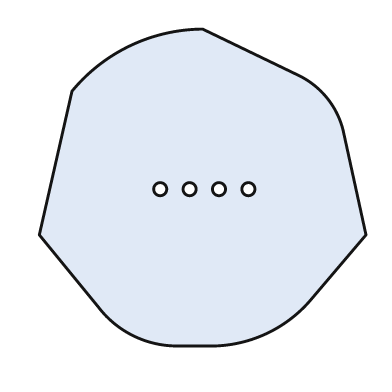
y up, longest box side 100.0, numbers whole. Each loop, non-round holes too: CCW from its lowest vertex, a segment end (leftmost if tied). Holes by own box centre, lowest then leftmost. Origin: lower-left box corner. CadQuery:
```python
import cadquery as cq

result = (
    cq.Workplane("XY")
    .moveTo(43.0, 0.0)
    .lineTo(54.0, 0.0)
    .threePointArc((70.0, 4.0), (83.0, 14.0))
    .lineTo(100.0, 34.0)
    .lineTo(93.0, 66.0)
    .threePointArc((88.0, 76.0), (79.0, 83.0))
    .lineTo(50.0, 97.0)
    .threePointArc((28.0, 92.0), (10.0, 78.0))
    .lineTo(0.0, 34.0)
    .lineTo(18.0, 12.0)
    .threePointArc((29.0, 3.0), (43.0, 0.0))
    .close()
    .moveTo(37.0, 48.0)
    .circle(2.0)
    .moveTo(46.0, 48.0)
    .circle(2.0)
    .moveTo(55.0, 48.0)
    .circle(2.0)
    .moveTo(64.0, 48.0)
    .circle(2.0)
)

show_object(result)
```